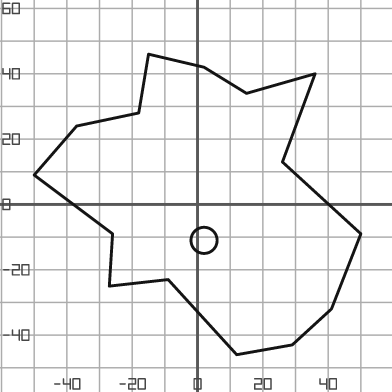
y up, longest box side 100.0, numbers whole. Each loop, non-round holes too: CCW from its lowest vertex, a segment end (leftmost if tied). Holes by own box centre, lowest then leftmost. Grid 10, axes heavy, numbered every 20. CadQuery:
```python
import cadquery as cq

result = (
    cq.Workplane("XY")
    .moveTo(12.0, -46.0)
    .lineTo(29.0, -43.0)
    .lineTo(41.0, -32.0)
    .lineTo(50.0, -9.0)
    .lineTo(26.0, 13.0)
    .lineTo(36.0, 40.0)
    .lineTo(15.0, 34.0)
    .lineTo(2.0, 42.0)
    .lineTo(-15.0, 46.0)
    .lineTo(-18.0, 28.0)
    .lineTo(-37.0, 24.0)
    .lineTo(-50.0, 9.0)
    .lineTo(-26.0, -9.0)
    .lineTo(-27.0, -25.0)
    .lineTo(-9.0, -23.0)
    .close()
    .moveTo(2.0, -11.0)
    .circle(4.0)
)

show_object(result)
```